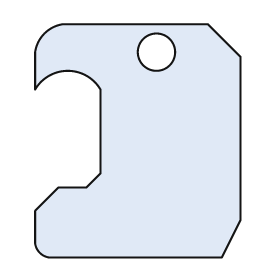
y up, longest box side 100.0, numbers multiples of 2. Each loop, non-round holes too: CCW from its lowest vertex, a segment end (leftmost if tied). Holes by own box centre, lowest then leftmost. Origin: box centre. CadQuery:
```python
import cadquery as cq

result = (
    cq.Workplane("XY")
    .moveTo(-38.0, -50.0)
    .lineTo(36.0, -50.0)
    .lineTo(44.0, -34.0)
    .lineTo(44.0, 36.0)
    .lineTo(30.0, 50.0)
    .lineTo(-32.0, 50.0)
    .threePointArc((-40.0, 46.0), (-44.0, 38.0))
    .lineTo(-44.0, 22.0)
    .threePointArc((-30.0, 30.0), (-16.0, 22.0))
    .lineTo(-16.0, -14.0)
    .lineTo(-22.0, -20.0)
    .lineTo(-34.0, -20.0)
    .lineTo(-44.0, -30.0)
    .lineTo(-44.0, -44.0)
    .threePointArc((-42.0, -48.0), (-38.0, -50.0))
    .close()
    .moveTo(8.0, 38.0)
    .circle(8.0)
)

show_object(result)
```